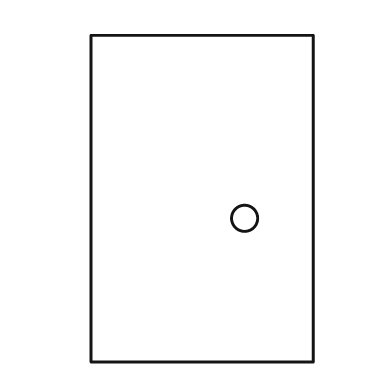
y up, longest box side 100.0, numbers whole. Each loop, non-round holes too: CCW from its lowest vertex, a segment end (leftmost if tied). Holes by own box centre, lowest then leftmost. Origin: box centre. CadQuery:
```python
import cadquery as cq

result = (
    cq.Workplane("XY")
    .moveTo(-34.0, -50.0)
    .lineTo(34.0, -50.0)
    .lineTo(34.0, 50.0)
    .lineTo(-34.0, 50.0)
    .close()
    .moveTo(13.0, -6.0)
    .circle(4.0)
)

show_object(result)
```